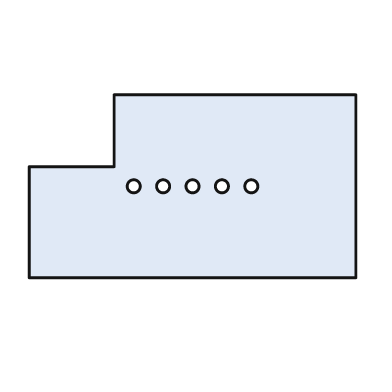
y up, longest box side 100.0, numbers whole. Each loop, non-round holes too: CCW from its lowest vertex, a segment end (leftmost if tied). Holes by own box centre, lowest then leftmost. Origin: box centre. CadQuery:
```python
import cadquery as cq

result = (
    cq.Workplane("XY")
    .moveTo(-50.0, -28.0)
    .lineTo(50.0, -28.0)
    .lineTo(50.0, 28.0)
    .lineTo(-24.0, 28.0)
    .lineTo(-24.0, 6.0)
    .lineTo(-50.0, 6.0)
    .close()
    .moveTo(-18.0, 0.0)
    .circle(2.0)
    .moveTo(-9.0, 0.0)
    .circle(2.0)
    .moveTo(0.0, 0.0)
    .circle(2.0)
    .moveTo(9.0, 0.0)
    .circle(2.0)
    .moveTo(18.0, 0.0)
    .circle(2.0)
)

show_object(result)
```